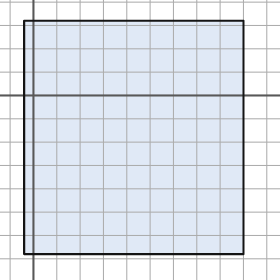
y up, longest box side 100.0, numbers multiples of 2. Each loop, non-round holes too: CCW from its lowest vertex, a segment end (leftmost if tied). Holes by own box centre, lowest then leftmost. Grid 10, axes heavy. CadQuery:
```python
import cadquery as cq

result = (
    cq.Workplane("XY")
    .moveTo(-4.0, -68.0)
    .lineTo(90.0, -68.0)
    .lineTo(90.0, 32.0)
    .lineTo(-4.0, 32.0)
    .close()
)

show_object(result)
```